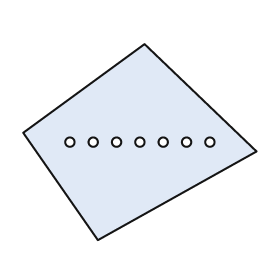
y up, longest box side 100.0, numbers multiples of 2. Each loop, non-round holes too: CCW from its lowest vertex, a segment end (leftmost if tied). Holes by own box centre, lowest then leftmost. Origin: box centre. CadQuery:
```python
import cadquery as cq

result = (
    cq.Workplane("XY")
    .moveTo(-18.0, -42.0)
    .lineTo(50.0, -4.0)
    .lineTo(2.0, 42.0)
    .lineTo(-50.0, 4.0)
    .close()
    .moveTo(-30.0, 0.0)
    .circle(2.0)
    .moveTo(-20.0, 0.0)
    .circle(2.0)
    .moveTo(-10.0, 0.0)
    .circle(2.0)
    .moveTo(0.0, 0.0)
    .circle(2.0)
    .moveTo(10.0, 0.0)
    .circle(2.0)
    .moveTo(20.0, 0.0)
    .circle(2.0)
    .moveTo(30.0, 0.0)
    .circle(2.0)
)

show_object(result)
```